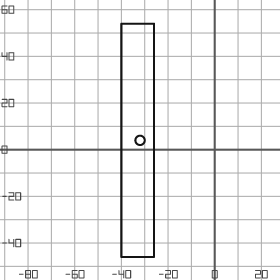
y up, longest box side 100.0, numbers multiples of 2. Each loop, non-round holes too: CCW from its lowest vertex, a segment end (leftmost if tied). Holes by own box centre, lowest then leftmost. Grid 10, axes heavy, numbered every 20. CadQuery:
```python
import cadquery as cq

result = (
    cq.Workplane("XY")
    .moveTo(-40.0, -46.0)
    .lineTo(-26.0, -46.0)
    .lineTo(-26.0, 54.0)
    .lineTo(-40.0, 54.0)
    .close()
    .moveTo(-32.0, 4.0)
    .circle(2.0)
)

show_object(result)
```